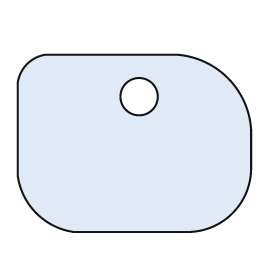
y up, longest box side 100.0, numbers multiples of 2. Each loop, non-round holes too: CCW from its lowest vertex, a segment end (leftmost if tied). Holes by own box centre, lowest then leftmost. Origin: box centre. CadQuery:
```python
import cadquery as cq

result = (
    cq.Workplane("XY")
    .moveTo(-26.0, -38.0)
    .lineTo(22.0, -38.0)
    .threePointArc((42.0, -30.0), (50.0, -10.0))
    .lineTo(50.0, 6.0)
    .threePointArc((40.0, 28.0), (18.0, 38.0))
    .lineTo(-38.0, 38.0)
    .threePointArc((-46.0, 34.0), (-50.0, 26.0))
    .lineTo(-50.0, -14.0)
    .threePointArc((-42.0, -30.0), (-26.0, -38.0))
    .close()
    .moveTo(2.0, 20.0)
    .circle(8.0)
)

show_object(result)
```